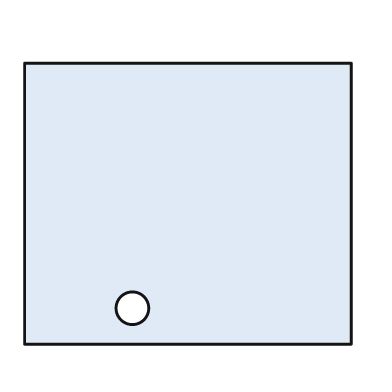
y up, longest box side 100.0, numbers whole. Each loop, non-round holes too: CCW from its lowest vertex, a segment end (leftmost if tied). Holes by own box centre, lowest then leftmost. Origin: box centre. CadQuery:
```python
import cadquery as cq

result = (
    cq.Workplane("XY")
    .moveTo(-50.0, -43.0)
    .lineTo(50.0, -43.0)
    .lineTo(50.0, 43.0)
    .lineTo(-50.0, 43.0)
    .close()
    .moveTo(-17.0, -32.0)
    .circle(5.0)
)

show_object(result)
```